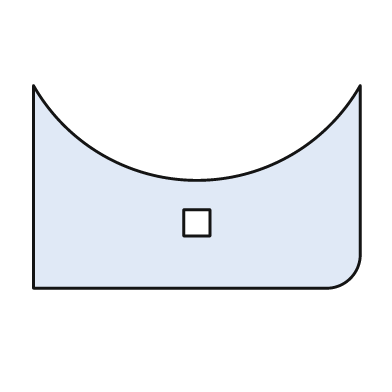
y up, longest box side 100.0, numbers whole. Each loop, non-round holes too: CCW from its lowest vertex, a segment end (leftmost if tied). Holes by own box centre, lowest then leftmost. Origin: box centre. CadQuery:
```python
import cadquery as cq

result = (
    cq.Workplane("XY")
    .moveTo(-50.0, -31.0)
    .lineTo(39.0, -31.0)
    .threePointArc((47.0, -28.0), (50.0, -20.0))
    .lineTo(50.0, 31.0)
    .threePointArc((0.0, 2.0), (-50.0, 31.0))
    .close()
    .moveTo(-4.0, -15.0)
    .lineTo(4.0, -15.0)
    .lineTo(4.0, -7.0)
    .lineTo(-4.0, -7.0)
    .close()
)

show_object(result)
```